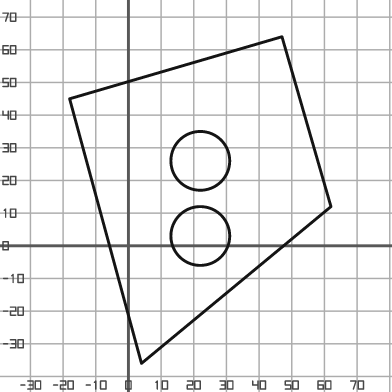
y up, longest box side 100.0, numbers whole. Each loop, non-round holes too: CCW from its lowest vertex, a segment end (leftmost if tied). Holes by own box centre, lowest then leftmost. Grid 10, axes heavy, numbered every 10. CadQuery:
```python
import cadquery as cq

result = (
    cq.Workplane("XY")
    .moveTo(4.0, -36.0)
    .lineTo(62.0, 12.0)
    .lineTo(47.0, 64.0)
    .lineTo(-18.0, 45.0)
    .close()
    .moveTo(22.0, 3.0)
    .circle(9.0)
    .moveTo(22.0, 26.0)
    .circle(9.0)
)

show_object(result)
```